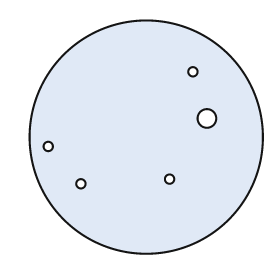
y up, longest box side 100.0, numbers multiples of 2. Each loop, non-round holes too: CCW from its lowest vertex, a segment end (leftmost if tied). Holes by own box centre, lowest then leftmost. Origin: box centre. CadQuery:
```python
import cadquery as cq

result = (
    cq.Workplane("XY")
    .moveTo(0.0, 0.0)
    .circle(50.0)
    .moveTo(-28.0, -20.0)
    .circle(2.0)
    .moveTo(10.0, -18.0)
    .circle(2.0)
    .moveTo(-42.0, -4.0)
    .circle(2.0)
    .moveTo(26.0, 8.0)
    .circle(4.0)
    .moveTo(20.0, 28.0)
    .circle(2.0)
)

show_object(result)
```